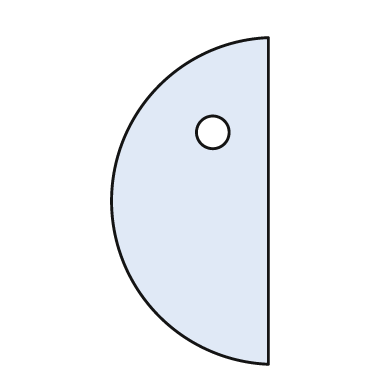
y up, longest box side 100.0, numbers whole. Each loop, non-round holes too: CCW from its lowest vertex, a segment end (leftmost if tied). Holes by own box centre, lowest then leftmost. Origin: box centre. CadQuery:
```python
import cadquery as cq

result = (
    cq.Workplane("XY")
    .moveTo(24.0, -50.0)
    .lineTo(24.0, 50.0)
    .threePointArc((-24.0, 0.0), (24.0, -50.0))
    .close()
    .moveTo(7.0, 21.0)
    .circle(5.0)
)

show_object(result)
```